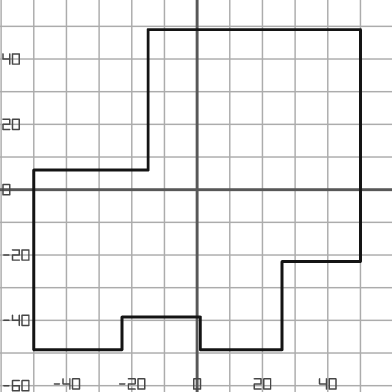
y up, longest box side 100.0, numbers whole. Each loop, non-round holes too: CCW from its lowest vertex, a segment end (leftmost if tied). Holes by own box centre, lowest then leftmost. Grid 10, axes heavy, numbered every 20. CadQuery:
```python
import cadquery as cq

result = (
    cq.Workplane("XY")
    .moveTo(-50.0, -49.0)
    .lineTo(-23.0, -49.0)
    .lineTo(-23.0, -39.0)
    .lineTo(1.0, -39.0)
    .lineTo(1.0, -49.0)
    .lineTo(26.0, -49.0)
    .lineTo(26.0, -22.0)
    .lineTo(50.0, -22.0)
    .lineTo(50.0, 49.0)
    .lineTo(-15.0, 49.0)
    .lineTo(-15.0, 6.0)
    .lineTo(-50.0, 6.0)
    .close()
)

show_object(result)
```